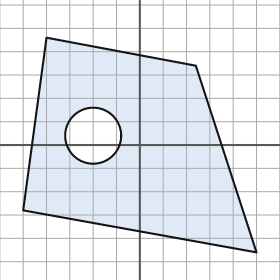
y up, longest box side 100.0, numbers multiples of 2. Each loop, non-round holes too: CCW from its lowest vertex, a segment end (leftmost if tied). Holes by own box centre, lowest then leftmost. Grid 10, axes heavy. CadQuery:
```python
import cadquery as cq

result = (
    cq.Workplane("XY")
    .moveTo(50.0, -46.0)
    .lineTo(24.0, 34.0)
    .lineTo(-40.0, 46.0)
    .lineTo(-50.0, -28.0)
    .close()
    .moveTo(-20.0, 4.0)
    .circle(12.0)
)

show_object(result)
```